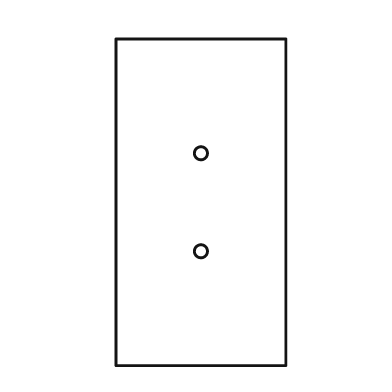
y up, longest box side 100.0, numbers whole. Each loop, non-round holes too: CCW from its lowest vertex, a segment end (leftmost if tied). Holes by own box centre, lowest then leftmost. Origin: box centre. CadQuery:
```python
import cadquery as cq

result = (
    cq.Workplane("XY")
    .moveTo(-26.0, -50.0)
    .lineTo(26.0, -50.0)
    .lineTo(26.0, 50.0)
    .lineTo(-26.0, 50.0)
    .close()
    .moveTo(0.0, -15.0)
    .circle(2.0)
    .moveTo(0.0, 15.0)
    .circle(2.0)
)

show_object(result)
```